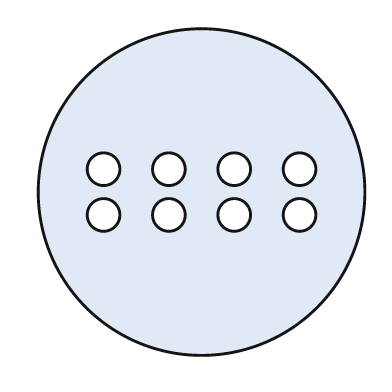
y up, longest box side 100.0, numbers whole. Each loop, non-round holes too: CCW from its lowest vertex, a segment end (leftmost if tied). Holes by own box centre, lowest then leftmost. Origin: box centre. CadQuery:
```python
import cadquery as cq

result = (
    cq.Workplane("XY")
    .moveTo(0.0, 0.0)
    .circle(50.0)
    .moveTo(-30.0, -7.0)
    .circle(5.0)
    .moveTo(-10.0, -7.0)
    .circle(5.0)
    .moveTo(10.0, -7.0)
    .circle(5.0)
    .moveTo(30.0, -7.0)
    .circle(5.0)
    .moveTo(-30.0, 7.0)
    .circle(5.0)
    .moveTo(-10.0, 7.0)
    .circle(5.0)
    .moveTo(10.0, 7.0)
    .circle(5.0)
    .moveTo(30.0, 7.0)
    .circle(5.0)
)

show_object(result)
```